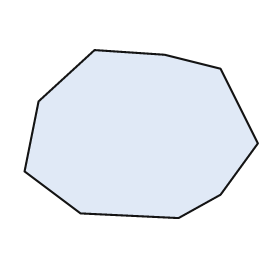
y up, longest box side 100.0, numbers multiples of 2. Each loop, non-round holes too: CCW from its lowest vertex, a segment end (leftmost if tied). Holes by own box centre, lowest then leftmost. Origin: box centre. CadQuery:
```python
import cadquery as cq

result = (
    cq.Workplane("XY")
    .moveTo(16.0, -36.0)
    .lineTo(34.0, -26.0)
    .lineTo(50.0, -4.0)
    .lineTo(34.0, 28.0)
    .lineTo(10.0, 34.0)
    .lineTo(-20.0, 36.0)
    .lineTo(-44.0, 14.0)
    .lineTo(-50.0, -16.0)
    .lineTo(-26.0, -34.0)
    .close()
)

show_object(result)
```